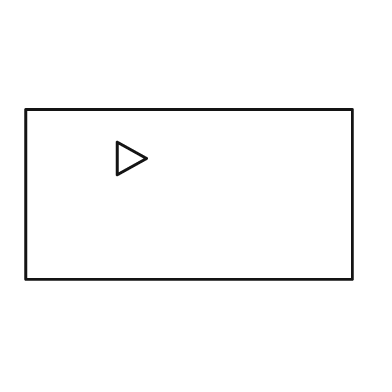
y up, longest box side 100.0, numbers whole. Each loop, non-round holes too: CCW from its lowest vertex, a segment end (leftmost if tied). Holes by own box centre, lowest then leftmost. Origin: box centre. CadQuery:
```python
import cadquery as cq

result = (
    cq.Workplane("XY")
    .moveTo(-50.0, -26.0)
    .lineTo(50.0, -26.0)
    .lineTo(50.0, 26.0)
    .lineTo(-50.0, 26.0)
    .close()
    .moveTo(-22.0, 6.0)
    .lineTo(-13.0, 11.0)
    .lineTo(-22.0, 16.0)
    .close()
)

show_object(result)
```